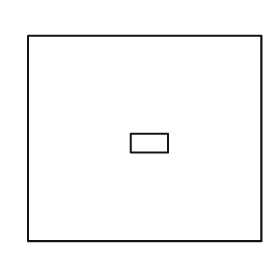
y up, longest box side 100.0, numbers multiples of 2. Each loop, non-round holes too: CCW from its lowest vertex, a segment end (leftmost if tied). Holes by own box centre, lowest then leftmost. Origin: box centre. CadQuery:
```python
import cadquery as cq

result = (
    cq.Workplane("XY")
    .moveTo(-50.0, -44.0)
    .lineTo(50.0, -44.0)
    .lineTo(50.0, 44.0)
    .lineTo(-50.0, 44.0)
    .close()
    .moveTo(-6.0, -6.0)
    .lineTo(10.0, -6.0)
    .lineTo(10.0, 2.0)
    .lineTo(-6.0, 2.0)
    .close()
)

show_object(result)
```